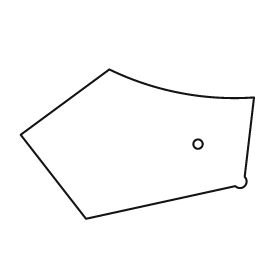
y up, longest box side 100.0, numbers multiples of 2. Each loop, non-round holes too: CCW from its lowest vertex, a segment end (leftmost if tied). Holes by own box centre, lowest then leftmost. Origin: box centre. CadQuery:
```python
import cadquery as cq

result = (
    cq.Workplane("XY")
    .moveTo(-22.0, -32.0)
    .lineTo(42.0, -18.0)
    .threePointArc((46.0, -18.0), (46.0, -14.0))
    .lineTo(50.0, 20.0)
    .threePointArc((18.0, 22.0), (-12.0, 32.0))
    .lineTo(-50.0, 4.0)
    .close()
    .moveTo(26.0, 0.0)
    .circle(2.0)
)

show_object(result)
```